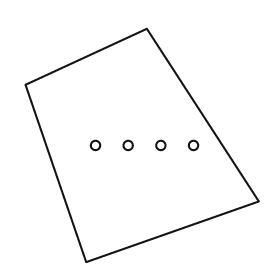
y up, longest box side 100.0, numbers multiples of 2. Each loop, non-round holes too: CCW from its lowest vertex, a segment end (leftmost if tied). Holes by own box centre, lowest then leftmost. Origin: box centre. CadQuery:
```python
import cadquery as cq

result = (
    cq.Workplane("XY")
    .moveTo(-24.0, -50.0)
    .lineTo(50.0, -24.0)
    .lineTo(2.0, 50.0)
    .lineTo(-50.0, 26.0)
    .close()
    .moveTo(-20.0, 0.0)
    .circle(2.0)
    .moveTo(-6.0, 0.0)
    .circle(2.0)
    .moveTo(8.0, 0.0)
    .circle(2.0)
    .moveTo(22.0, 0.0)
    .circle(2.0)
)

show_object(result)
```